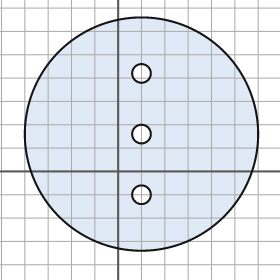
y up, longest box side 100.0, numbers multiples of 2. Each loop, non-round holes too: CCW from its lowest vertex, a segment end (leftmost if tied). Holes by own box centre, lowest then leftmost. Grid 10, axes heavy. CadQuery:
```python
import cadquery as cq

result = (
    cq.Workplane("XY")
    .moveTo(10.0, 16.0)
    .circle(50.0)
    .moveTo(10.0, -10.0)
    .circle(4.0)
    .moveTo(10.0, 16.0)
    .circle(4.0)
    .moveTo(10.0, 42.0)
    .circle(4.0)
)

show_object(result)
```